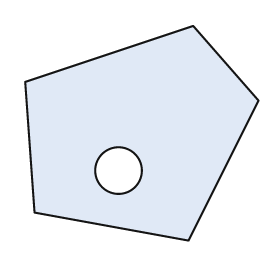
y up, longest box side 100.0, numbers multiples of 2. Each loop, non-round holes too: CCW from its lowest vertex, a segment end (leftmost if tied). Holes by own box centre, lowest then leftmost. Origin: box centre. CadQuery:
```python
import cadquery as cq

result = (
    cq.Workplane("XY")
    .moveTo(20.0, -46.0)
    .lineTo(50.0, 14.0)
    .lineTo(22.0, 46.0)
    .lineTo(-50.0, 22.0)
    .lineTo(-46.0, -34.0)
    .close()
    .moveTo(-10.0, -16.0)
    .circle(10.0)
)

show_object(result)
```